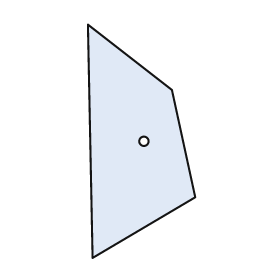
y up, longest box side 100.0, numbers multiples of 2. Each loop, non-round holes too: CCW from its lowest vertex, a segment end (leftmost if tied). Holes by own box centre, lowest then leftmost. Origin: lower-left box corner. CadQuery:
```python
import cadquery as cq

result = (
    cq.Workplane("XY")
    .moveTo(2.0, 0.0)
    .lineTo(46.0, 26.0)
    .lineTo(36.0, 72.0)
    .lineTo(0.0, 100.0)
    .close()
    .moveTo(24.0, 50.0)
    .circle(2.0)
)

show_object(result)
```